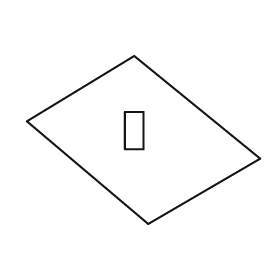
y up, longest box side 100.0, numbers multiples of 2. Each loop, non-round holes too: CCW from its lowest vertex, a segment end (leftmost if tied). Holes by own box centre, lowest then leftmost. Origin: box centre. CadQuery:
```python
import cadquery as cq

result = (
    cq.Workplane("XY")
    .moveTo(2.0, -36.0)
    .lineTo(50.0, -8.0)
    .lineTo(-4.0, 36.0)
    .lineTo(-50.0, 8.0)
    .close()
    .moveTo(-8.0, -4.0)
    .lineTo(0.0, -4.0)
    .lineTo(0.0, 12.0)
    .lineTo(-8.0, 12.0)
    .close()
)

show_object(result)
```